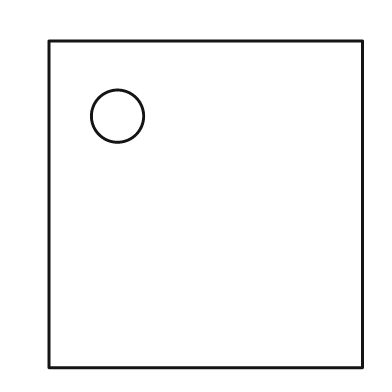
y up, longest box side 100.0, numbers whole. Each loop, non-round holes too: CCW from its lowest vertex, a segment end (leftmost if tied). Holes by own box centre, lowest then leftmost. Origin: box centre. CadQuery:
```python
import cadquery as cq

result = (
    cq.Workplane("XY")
    .moveTo(-48.0, -50.0)
    .lineTo(48.0, -50.0)
    .lineTo(48.0, 50.0)
    .lineTo(-48.0, 50.0)
    .close()
    .moveTo(-27.0, 27.0)
    .circle(8.0)
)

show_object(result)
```